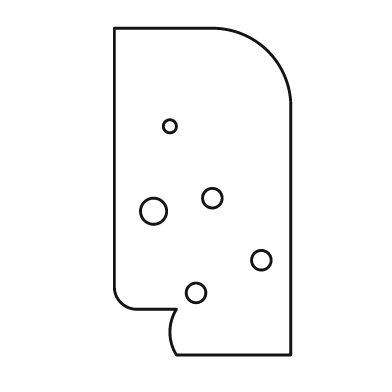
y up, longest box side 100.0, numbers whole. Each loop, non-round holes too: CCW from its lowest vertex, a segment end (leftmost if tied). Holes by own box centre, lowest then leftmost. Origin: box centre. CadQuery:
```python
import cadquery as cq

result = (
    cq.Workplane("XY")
    .moveTo(-8.0, -50.0)
    .lineTo(27.0, -50.0)
    .lineTo(27.0, 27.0)
    .threePointArc((20.0, 43.0), (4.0, 50.0))
    .lineTo(-27.0, 50.0)
    .lineTo(-27.0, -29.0)
    .threePointArc((-25.0, -34.0), (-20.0, -36.0))
    .lineTo(-8.0, -36.0)
    .threePointArc((-10.0, -43.0), (-8.0, -50.0))
    .close()
    .moveTo(-2.0, -31.0)
    .circle(3.0)
    .moveTo(18.0, -21.0)
    .circle(3.0)
    .moveTo(-15.0, -6.0)
    .circle(4.0)
    .moveTo(3.0, -2.0)
    .circle(3.0)
    .moveTo(-10.0, 20.0)
    .circle(2.0)
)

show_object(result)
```